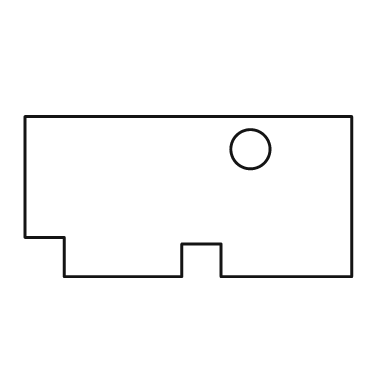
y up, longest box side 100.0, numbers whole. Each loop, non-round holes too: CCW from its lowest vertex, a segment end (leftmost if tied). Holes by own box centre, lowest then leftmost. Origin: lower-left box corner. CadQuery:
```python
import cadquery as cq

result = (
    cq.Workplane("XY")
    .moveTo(12.0, 0.0)
    .lineTo(48.0, 0.0)
    .lineTo(48.0, 10.0)
    .lineTo(60.0, 10.0)
    .lineTo(60.0, 0.0)
    .lineTo(100.0, 0.0)
    .lineTo(100.0, 49.0)
    .lineTo(0.0, 49.0)
    .lineTo(0.0, 12.0)
    .lineTo(12.0, 12.0)
    .close()
    .moveTo(69.0, 39.0)
    .circle(6.0)
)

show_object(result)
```